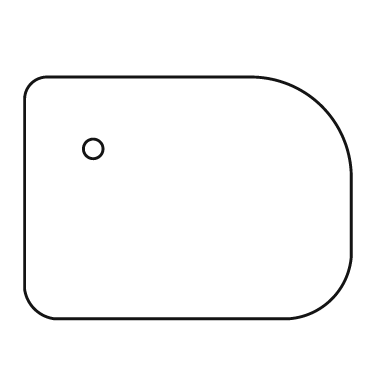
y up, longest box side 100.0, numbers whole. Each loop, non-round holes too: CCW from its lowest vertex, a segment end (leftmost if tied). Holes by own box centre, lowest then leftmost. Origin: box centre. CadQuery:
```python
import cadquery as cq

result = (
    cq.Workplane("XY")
    .moveTo(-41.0, -37.0)
    .lineTo(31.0, -37.0)
    .threePointArc((44.0, -31.0), (50.0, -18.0))
    .lineTo(50.0, 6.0)
    .threePointArc((41.0, 28.0), (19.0, 37.0))
    .lineTo(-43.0, 37.0)
    .threePointArc((-48.0, 35.0), (-50.0, 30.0))
    .lineTo(-50.0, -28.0)
    .threePointArc((-47.0, -34.0), (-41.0, -37.0))
    .close()
    .moveTo(-29.0, 15.0)
    .circle(3.0)
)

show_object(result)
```